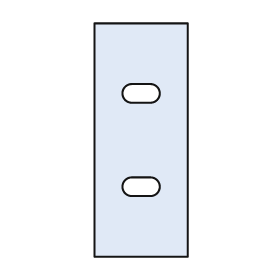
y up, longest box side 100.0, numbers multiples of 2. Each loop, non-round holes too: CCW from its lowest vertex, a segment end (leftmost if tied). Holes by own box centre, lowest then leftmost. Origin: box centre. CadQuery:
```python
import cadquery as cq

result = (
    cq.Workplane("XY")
    .moveTo(-20.0, -50.0)
    .lineTo(20.0, -50.0)
    .lineTo(20.0, 50.0)
    .lineTo(-20.0, 50.0)
    .close()
    .moveTo(-4.0, -24.0)
    .lineTo(4.0, -24.0)
    .threePointArc((8.0, -20.0), (4.0, -16.0))
    .lineTo(-4.0, -16.0)
    .threePointArc((-8.0, -20.0), (-4.0, -24.0))
    .close()
    .moveTo(-4.0, 16.0)
    .lineTo(4.0, 16.0)
    .threePointArc((8.0, 20.0), (4.0, 24.0))
    .lineTo(-4.0, 24.0)
    .threePointArc((-8.0, 20.0), (-4.0, 16.0))
    .close()
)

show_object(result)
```